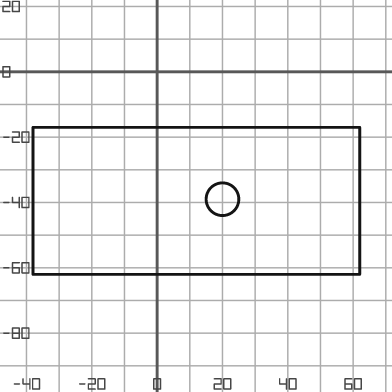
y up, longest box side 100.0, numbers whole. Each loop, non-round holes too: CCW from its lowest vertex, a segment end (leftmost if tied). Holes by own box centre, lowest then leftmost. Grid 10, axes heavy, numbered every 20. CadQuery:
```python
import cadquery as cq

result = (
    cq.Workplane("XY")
    .moveTo(-38.0, -62.0)
    .lineTo(62.0, -62.0)
    .lineTo(62.0, -17.0)
    .lineTo(-38.0, -17.0)
    .close()
    .moveTo(20.0, -39.0)
    .circle(5.0)
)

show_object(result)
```